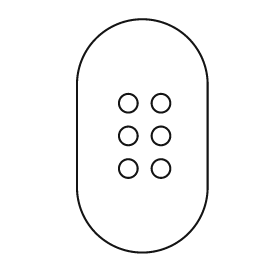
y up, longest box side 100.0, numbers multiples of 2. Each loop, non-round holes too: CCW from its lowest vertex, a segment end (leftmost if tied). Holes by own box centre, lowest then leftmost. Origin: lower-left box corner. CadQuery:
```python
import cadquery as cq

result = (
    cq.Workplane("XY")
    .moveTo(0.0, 28.0)
    .threePointArc((28.0, 0.0), (56.0, 28.0))
    .lineTo(56.0, 72.0)
    .threePointArc((28.0, 100.0), (0.0, 72.0))
    .close()
    .moveTo(22.0, 36.0)
    .circle(4.0)
    .moveTo(36.0, 36.0)
    .circle(4.0)
    .moveTo(22.0, 50.0)
    .circle(4.0)
    .moveTo(36.0, 50.0)
    .circle(4.0)
    .moveTo(22.0, 64.0)
    .circle(4.0)
    .moveTo(36.0, 64.0)
    .circle(4.0)
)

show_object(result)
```